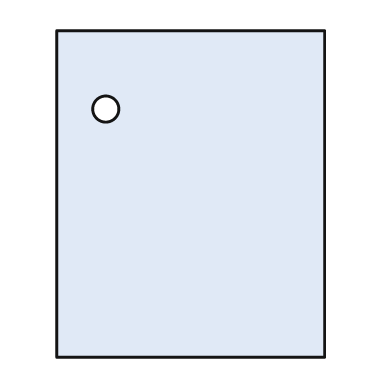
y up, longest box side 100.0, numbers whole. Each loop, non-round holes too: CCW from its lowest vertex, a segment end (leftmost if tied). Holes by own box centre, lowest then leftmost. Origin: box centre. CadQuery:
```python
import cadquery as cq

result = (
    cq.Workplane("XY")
    .moveTo(-41.0, -50.0)
    .lineTo(41.0, -50.0)
    .lineTo(41.0, 50.0)
    .lineTo(-41.0, 50.0)
    .close()
    .moveTo(-26.0, 26.0)
    .circle(4.0)
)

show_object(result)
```